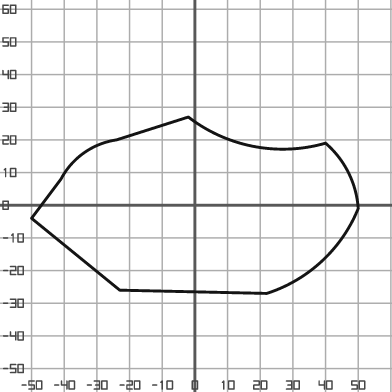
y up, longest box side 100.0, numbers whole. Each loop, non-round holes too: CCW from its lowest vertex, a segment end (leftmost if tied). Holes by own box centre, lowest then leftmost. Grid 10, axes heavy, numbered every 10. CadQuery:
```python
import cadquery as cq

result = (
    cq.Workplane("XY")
    .moveTo(22.0, -27.0)
    .threePointArc((39.0, -17.0), (50.0, -1.0))
    .threePointArc((47.0, 10.0), (40.0, 19.0))
    .threePointArc((18.0, 18.0), (-2.0, 27.0))
    .lineTo(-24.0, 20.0)
    .threePointArc((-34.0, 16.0), (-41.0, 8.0))
    .lineTo(-50.0, -4.0)
    .lineTo(-23.0, -26.0)
    .close()
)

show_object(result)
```